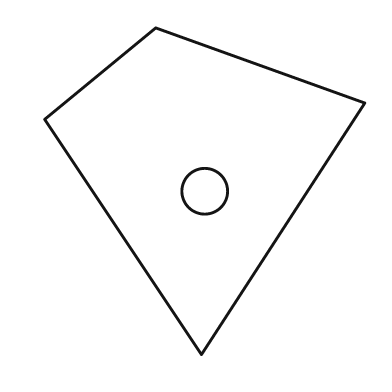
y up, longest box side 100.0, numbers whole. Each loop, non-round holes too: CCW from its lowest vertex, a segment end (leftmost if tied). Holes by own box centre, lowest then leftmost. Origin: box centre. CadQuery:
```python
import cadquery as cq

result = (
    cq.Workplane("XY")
    .moveTo(-1.0, -50.0)
    .lineTo(49.0, 27.0)
    .lineTo(-15.0, 50.0)
    .lineTo(-49.0, 22.0)
    .close()
    .moveTo(0.0, 0.0)
    .circle(7.0)
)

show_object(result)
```